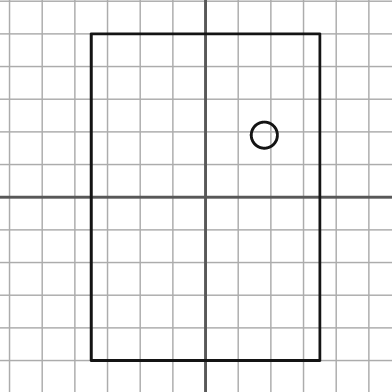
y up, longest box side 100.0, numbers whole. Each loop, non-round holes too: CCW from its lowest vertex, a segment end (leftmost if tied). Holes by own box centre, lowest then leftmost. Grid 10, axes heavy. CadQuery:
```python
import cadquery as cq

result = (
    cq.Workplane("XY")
    .moveTo(-35.0, -50.0)
    .lineTo(35.0, -50.0)
    .lineTo(35.0, 50.0)
    .lineTo(-35.0, 50.0)
    .close()
    .moveTo(18.0, 19.0)
    .circle(4.0)
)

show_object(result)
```